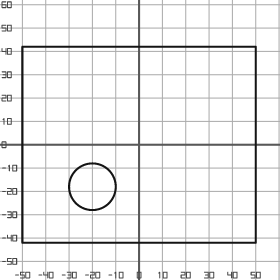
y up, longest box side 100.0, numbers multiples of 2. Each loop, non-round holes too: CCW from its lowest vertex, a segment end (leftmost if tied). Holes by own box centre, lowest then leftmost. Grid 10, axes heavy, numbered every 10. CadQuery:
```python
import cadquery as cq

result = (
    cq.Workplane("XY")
    .moveTo(-50.0, -42.0)
    .lineTo(50.0, -42.0)
    .lineTo(50.0, 42.0)
    .lineTo(-50.0, 42.0)
    .close()
    .moveTo(-20.0, -18.0)
    .circle(10.0)
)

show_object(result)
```